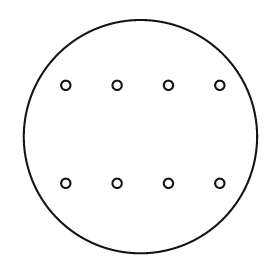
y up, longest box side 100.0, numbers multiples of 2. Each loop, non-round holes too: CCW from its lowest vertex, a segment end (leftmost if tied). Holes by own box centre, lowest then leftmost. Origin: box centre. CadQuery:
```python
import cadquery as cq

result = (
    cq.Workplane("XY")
    .moveTo(0.0, 0.0)
    .circle(50.0)
    .moveTo(-32.0, -20.0)
    .circle(2.0)
    .moveTo(-10.0, -20.0)
    .circle(2.0)
    .moveTo(12.0, -20.0)
    .circle(2.0)
    .moveTo(34.0, -20.0)
    .circle(2.0)
    .moveTo(-32.0, 22.0)
    .circle(2.0)
    .moveTo(-10.0, 22.0)
    .circle(2.0)
    .moveTo(12.0, 22.0)
    .circle(2.0)
    .moveTo(34.0, 22.0)
    .circle(2.0)
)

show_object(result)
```